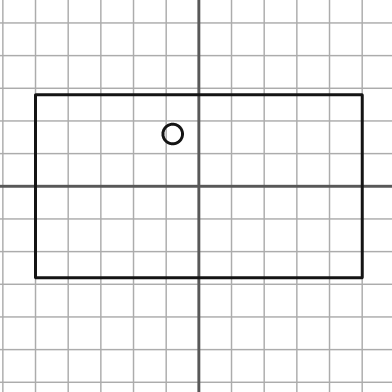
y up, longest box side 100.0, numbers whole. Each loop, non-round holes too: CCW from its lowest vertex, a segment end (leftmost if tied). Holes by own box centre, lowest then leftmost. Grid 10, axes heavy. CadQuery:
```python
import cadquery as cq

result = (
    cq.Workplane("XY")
    .moveTo(-50.0, -28.0)
    .lineTo(50.0, -28.0)
    .lineTo(50.0, 28.0)
    .lineTo(-50.0, 28.0)
    .close()
    .moveTo(-8.0, 16.0)
    .circle(3.0)
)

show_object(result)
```